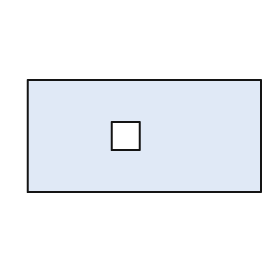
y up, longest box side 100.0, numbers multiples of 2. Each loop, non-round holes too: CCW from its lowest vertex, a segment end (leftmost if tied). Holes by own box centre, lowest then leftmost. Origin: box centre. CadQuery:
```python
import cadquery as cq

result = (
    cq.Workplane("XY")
    .moveTo(-50.0, -24.0)
    .lineTo(50.0, -24.0)
    .lineTo(50.0, 24.0)
    .lineTo(-50.0, 24.0)
    .close()
    .moveTo(-14.0, -6.0)
    .lineTo(-2.0, -6.0)
    .lineTo(-2.0, 6.0)
    .lineTo(-14.0, 6.0)
    .close()
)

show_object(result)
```